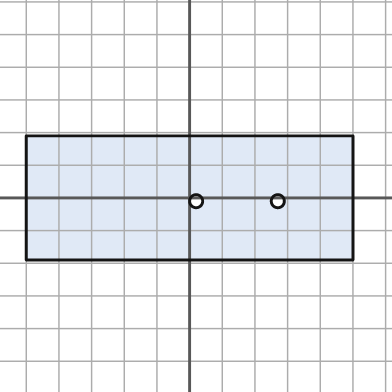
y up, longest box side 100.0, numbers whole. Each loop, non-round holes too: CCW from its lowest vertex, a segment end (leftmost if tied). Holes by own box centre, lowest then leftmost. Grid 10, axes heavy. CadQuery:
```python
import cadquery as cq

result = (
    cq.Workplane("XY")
    .moveTo(-50.0, -19.0)
    .lineTo(50.0, -19.0)
    .lineTo(50.0, 19.0)
    .lineTo(-50.0, 19.0)
    .close()
    .moveTo(2.0, -1.0)
    .circle(2.0)
    .moveTo(27.0, -1.0)
    .circle(2.0)
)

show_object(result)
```